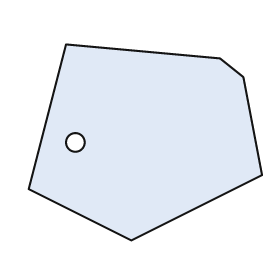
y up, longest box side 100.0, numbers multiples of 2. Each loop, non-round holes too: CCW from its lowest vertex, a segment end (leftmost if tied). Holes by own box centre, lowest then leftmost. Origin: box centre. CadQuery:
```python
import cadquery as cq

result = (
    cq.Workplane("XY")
    .moveTo(-6.0, -42.0)
    .lineTo(50.0, -14.0)
    .lineTo(42.0, 28.0)
    .lineTo(32.0, 36.0)
    .lineTo(-34.0, 42.0)
    .lineTo(-50.0, -20.0)
    .close()
    .moveTo(-30.0, 0.0)
    .circle(4.0)
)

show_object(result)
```